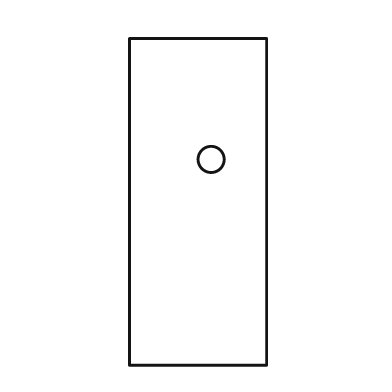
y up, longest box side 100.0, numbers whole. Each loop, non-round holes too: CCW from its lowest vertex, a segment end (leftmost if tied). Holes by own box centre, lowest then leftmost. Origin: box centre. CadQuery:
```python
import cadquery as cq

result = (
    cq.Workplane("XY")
    .moveTo(-21.0, -50.0)
    .lineTo(21.0, -50.0)
    .lineTo(21.0, 50.0)
    .lineTo(-21.0, 50.0)
    .close()
    .moveTo(4.0, 13.0)
    .circle(4.0)
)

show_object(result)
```